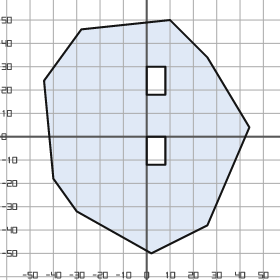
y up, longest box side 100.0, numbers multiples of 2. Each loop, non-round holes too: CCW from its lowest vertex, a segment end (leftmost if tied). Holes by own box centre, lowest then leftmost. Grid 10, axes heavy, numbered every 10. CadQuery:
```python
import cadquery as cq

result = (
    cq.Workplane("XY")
    .moveTo(2.0, -50.0)
    .lineTo(26.0, -38.0)
    .lineTo(44.0, 4.0)
    .lineTo(26.0, 34.0)
    .lineTo(10.0, 50.0)
    .lineTo(-28.0, 46.0)
    .lineTo(-44.0, 24.0)
    .lineTo(-40.0, -18.0)
    .lineTo(-30.0, -32.0)
    .close()
    .moveTo(0.0, -12.0)
    .lineTo(8.0, -12.0)
    .lineTo(8.0, 0.0)
    .lineTo(0.0, 0.0)
    .close()
    .moveTo(0.0, 18.0)
    .lineTo(8.0, 18.0)
    .lineTo(8.0, 30.0)
    .lineTo(0.0, 30.0)
    .close()
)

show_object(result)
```